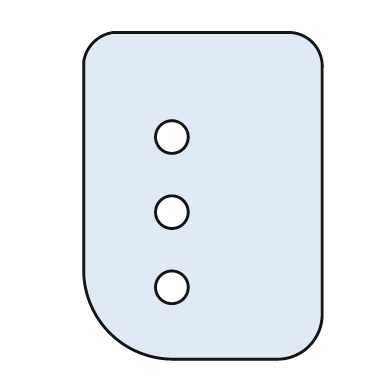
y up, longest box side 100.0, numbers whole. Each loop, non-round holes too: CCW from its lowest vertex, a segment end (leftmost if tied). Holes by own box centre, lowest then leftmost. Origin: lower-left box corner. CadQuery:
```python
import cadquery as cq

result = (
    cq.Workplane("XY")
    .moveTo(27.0, 0.0)
    .lineTo(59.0, 0.0)
    .threePointArc((69.0, 4.0), (73.0, 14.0))
    .lineTo(73.0, 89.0)
    .threePointArc((70.0, 97.0), (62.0, 100.0))
    .lineTo(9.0, 100.0)
    .threePointArc((3.0, 97.0), (0.0, 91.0))
    .lineTo(0.0, 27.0)
    .threePointArc((8.0, 8.0), (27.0, 0.0))
    .close()
    .moveTo(27.0, 22.0)
    .circle(5.0)
    .moveTo(27.0, 45.0)
    .circle(5.0)
    .moveTo(27.0, 68.0)
    .circle(5.0)
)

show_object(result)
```